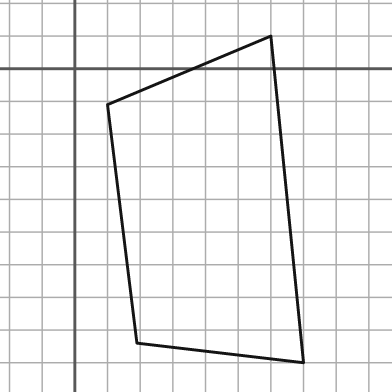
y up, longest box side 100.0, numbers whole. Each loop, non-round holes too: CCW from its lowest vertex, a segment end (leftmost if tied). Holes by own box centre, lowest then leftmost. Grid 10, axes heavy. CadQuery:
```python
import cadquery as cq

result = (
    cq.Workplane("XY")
    .moveTo(70.0, -90.0)
    .lineTo(60.0, 10.0)
    .lineTo(10.0, -11.0)
    .lineTo(19.0, -84.0)
    .close()
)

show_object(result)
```